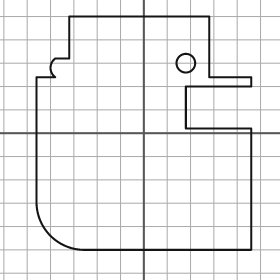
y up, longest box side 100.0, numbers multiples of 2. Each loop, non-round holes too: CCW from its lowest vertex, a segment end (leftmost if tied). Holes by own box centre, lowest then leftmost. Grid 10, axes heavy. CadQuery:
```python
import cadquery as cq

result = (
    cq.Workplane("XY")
    .moveTo(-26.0, -50.0)
    .lineTo(46.0, -50.0)
    .lineTo(46.0, 2.0)
    .lineTo(18.0, 2.0)
    .lineTo(18.0, 20.0)
    .lineTo(46.0, 20.0)
    .lineTo(46.0, 24.0)
    .lineTo(28.0, 24.0)
    .lineTo(28.0, 50.0)
    .lineTo(-32.0, 50.0)
    .lineTo(-32.0, 32.0)
    .lineTo(-38.0, 32.0)
    .threePointArc((-40.0, 28.0), (-38.0, 24.0))
    .lineTo(-46.0, 24.0)
    .lineTo(-46.0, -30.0)
    .threePointArc((-40.0, -44.0), (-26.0, -50.0))
    .close()
    .moveTo(18.0, 30.0)
    .circle(4.0)
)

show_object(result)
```